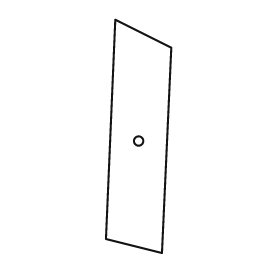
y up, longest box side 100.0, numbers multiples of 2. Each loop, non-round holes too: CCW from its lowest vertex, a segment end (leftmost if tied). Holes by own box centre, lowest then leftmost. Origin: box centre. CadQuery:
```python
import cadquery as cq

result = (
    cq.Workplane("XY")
    .moveTo(10.0, -50.0)
    .lineTo(14.0, 38.0)
    .lineTo(-10.0, 50.0)
    .lineTo(-14.0, -44.0)
    .close()
    .moveTo(0.0, -2.0)
    .circle(2.0)
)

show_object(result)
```